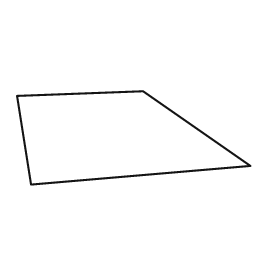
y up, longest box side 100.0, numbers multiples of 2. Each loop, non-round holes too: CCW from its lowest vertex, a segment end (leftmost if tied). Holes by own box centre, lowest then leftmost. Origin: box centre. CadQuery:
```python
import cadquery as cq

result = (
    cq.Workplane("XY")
    .moveTo(-44.0, -20.0)
    .lineTo(50.0, -12.0)
    .lineTo(4.0, 20.0)
    .lineTo(-50.0, 18.0)
    .close()
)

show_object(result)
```